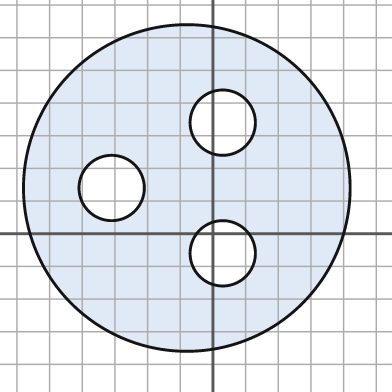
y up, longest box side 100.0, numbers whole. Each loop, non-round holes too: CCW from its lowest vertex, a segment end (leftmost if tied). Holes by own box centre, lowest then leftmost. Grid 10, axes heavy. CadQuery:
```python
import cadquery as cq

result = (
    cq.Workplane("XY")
    .moveTo(-8.0, 14.0)
    .circle(50.0)
    .moveTo(3.0, -6.0)
    .circle(10.0)
    .moveTo(-31.0, 14.0)
    .circle(10.0)
    .moveTo(3.0, 34.0)
    .circle(10.0)
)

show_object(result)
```